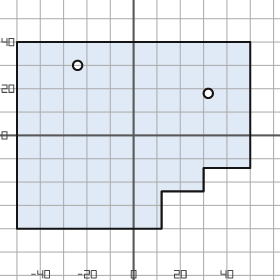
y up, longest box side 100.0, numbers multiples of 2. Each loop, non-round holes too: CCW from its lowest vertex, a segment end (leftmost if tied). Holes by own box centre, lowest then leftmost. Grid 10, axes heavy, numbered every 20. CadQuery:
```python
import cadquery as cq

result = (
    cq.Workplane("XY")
    .moveTo(-50.0, -40.0)
    .lineTo(12.0, -40.0)
    .lineTo(12.0, -24.0)
    .lineTo(30.0, -24.0)
    .lineTo(30.0, -14.0)
    .lineTo(50.0, -14.0)
    .lineTo(50.0, 40.0)
    .lineTo(-50.0, 40.0)
    .close()
    .moveTo(32.0, 18.0)
    .circle(2.0)
    .moveTo(-24.0, 30.0)
    .circle(2.0)
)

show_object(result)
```